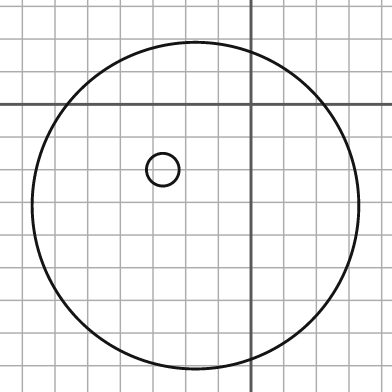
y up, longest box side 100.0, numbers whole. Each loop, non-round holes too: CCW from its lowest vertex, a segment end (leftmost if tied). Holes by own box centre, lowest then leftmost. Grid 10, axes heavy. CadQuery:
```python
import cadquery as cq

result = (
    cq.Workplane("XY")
    .moveTo(-17.0, -31.0)
    .circle(50.0)
    .moveTo(-27.0, -20.0)
    .circle(5.0)
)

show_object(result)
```